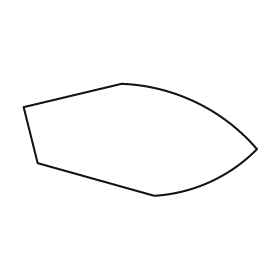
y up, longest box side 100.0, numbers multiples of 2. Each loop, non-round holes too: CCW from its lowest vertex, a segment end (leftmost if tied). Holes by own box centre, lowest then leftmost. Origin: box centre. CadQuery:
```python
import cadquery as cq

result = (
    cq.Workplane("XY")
    .moveTo(6.0, -24.0)
    .threePointArc((30.0, -18.0), (50.0, -4.0))
    .threePointArc((24.0, 16.0), (-8.0, 24.0))
    .lineTo(-50.0, 14.0)
    .lineTo(-44.0, -10.0)
    .close()
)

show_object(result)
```